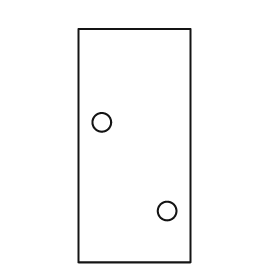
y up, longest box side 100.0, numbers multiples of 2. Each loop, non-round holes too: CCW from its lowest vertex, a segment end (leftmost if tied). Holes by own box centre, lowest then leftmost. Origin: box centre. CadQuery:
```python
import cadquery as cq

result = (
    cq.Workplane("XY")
    .moveTo(-24.0, -50.0)
    .lineTo(24.0, -50.0)
    .lineTo(24.0, 50.0)
    .lineTo(-24.0, 50.0)
    .close()
    .moveTo(14.0, -28.0)
    .circle(4.0)
    .moveTo(-14.0, 10.0)
    .circle(4.0)
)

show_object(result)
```